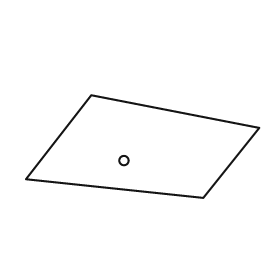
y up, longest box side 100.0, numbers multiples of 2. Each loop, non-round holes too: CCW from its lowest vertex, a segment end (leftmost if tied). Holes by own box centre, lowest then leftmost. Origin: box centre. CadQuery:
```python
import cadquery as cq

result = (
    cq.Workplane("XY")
    .moveTo(26.0, -22.0)
    .lineTo(50.0, 8.0)
    .lineTo(-22.0, 22.0)
    .lineTo(-50.0, -14.0)
    .close()
    .moveTo(-8.0, -6.0)
    .circle(2.0)
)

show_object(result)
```